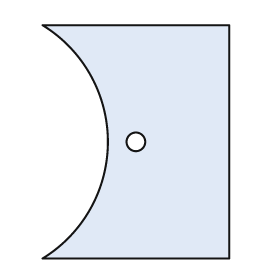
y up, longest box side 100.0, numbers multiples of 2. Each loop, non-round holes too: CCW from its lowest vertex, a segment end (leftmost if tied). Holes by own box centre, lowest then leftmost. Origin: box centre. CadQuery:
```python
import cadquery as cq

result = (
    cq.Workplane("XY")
    .moveTo(-40.0, -50.0)
    .lineTo(40.0, -50.0)
    .lineTo(40.0, 50.0)
    .lineTo(-40.0, 50.0)
    .threePointArc((-12.0, 0.0), (-40.0, -50.0))
    .close()
    .moveTo(0.0, 0.0)
    .circle(4.0)
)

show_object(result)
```